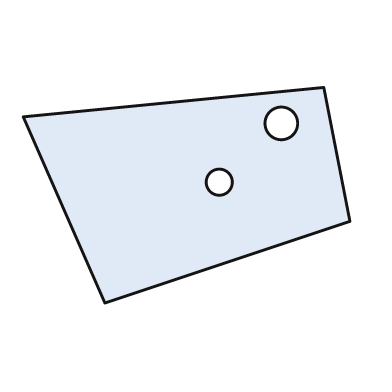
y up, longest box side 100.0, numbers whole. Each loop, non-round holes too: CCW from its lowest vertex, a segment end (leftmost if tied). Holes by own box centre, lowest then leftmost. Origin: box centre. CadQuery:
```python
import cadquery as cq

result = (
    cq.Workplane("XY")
    .moveTo(-25.0, -33.0)
    .lineTo(50.0, -8.0)
    .lineTo(42.0, 33.0)
    .lineTo(-50.0, 24.0)
    .close()
    .moveTo(10.0, 4.0)
    .circle(4.0)
    .moveTo(29.0, 22.0)
    .circle(5.0)
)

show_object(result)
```